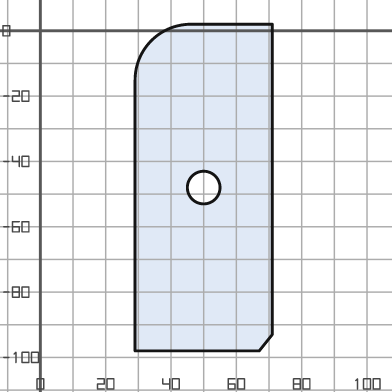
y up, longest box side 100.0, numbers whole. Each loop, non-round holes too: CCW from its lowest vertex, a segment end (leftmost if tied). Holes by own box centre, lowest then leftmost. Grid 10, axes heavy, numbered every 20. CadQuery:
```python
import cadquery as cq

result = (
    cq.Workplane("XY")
    .moveTo(29.0, -98.0)
    .lineTo(67.0, -98.0)
    .lineTo(71.0, -93.0)
    .lineTo(71.0, 2.0)
    .lineTo(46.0, 2.0)
    .threePointArc((34.0, -3.0), (29.0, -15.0))
    .close()
    .moveTo(50.0, -48.0)
    .circle(5.0)
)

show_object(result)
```